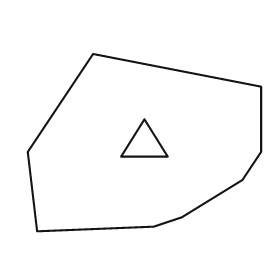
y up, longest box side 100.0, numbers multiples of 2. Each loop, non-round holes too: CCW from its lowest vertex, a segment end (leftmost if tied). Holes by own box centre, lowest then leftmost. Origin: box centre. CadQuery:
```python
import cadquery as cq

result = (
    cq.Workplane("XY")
    .moveTo(-46.0, -38.0)
    .lineTo(4.0, -36.0)
    .lineTo(16.0, -32.0)
    .lineTo(42.0, -16.0)
    .lineTo(50.0, -4.0)
    .lineTo(50.0, 24.0)
    .lineTo(-22.0, 38.0)
    .lineTo(-50.0, -4.0)
    .close()
    .moveTo(-10.0, -6.0)
    .lineTo(10.0, -6.0)
    .lineTo(0.0, 10.0)
    .close()
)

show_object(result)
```